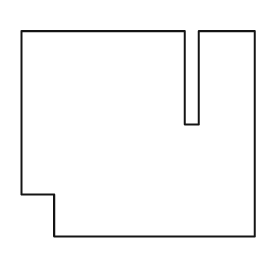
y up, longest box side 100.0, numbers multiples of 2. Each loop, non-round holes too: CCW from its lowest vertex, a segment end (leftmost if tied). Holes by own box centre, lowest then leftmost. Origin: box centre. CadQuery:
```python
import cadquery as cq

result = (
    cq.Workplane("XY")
    .moveTo(-36.0, -44.0)
    .lineTo(50.0, -44.0)
    .lineTo(50.0, 44.0)
    .lineTo(26.0, 44.0)
    .lineTo(26.0, 4.0)
    .lineTo(20.0, 4.0)
    .lineTo(20.0, 44.0)
    .lineTo(-50.0, 44.0)
    .lineTo(-50.0, -26.0)
    .lineTo(-36.0, -26.0)
    .close()
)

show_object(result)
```